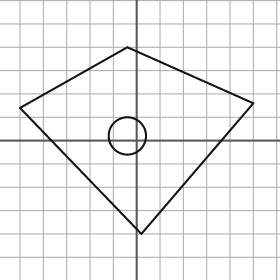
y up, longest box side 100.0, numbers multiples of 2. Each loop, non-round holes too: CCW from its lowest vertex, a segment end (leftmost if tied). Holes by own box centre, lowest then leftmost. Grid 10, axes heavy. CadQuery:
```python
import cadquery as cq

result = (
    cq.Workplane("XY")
    .moveTo(2.0, -40.0)
    .lineTo(50.0, 16.0)
    .lineTo(-4.0, 40.0)
    .lineTo(-50.0, 14.0)
    .close()
    .moveTo(-4.0, 2.0)
    .circle(8.0)
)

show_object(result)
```